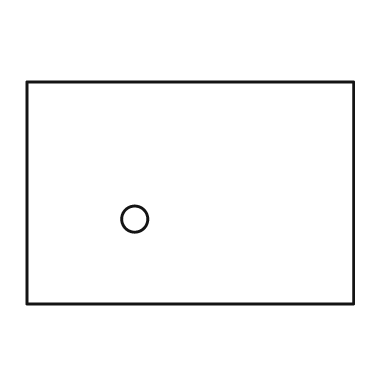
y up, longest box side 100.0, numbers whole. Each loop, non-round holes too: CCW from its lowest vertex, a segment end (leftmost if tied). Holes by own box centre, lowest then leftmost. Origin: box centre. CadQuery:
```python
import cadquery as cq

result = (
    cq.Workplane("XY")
    .moveTo(-50.0, -34.0)
    .lineTo(50.0, -34.0)
    .lineTo(50.0, 34.0)
    .lineTo(-50.0, 34.0)
    .close()
    .moveTo(-17.0, -8.0)
    .circle(4.0)
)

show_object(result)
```